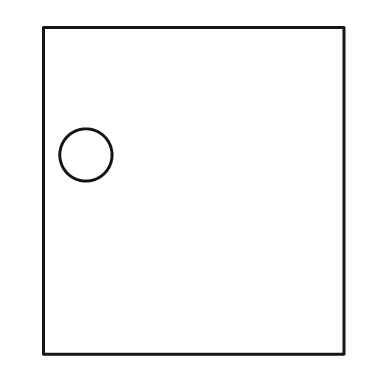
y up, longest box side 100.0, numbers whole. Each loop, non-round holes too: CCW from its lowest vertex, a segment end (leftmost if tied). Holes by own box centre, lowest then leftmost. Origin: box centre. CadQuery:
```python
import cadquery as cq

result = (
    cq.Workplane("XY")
    .moveTo(-46.0, -50.0)
    .lineTo(46.0, -50.0)
    .lineTo(46.0, 50.0)
    .lineTo(-46.0, 50.0)
    .close()
    .moveTo(-33.0, 11.0)
    .circle(8.0)
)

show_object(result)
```